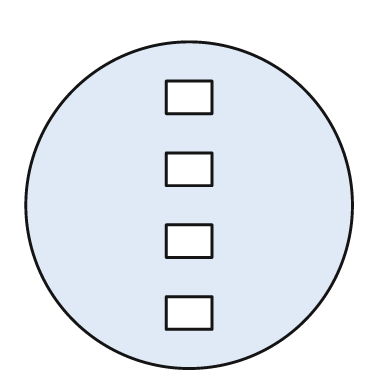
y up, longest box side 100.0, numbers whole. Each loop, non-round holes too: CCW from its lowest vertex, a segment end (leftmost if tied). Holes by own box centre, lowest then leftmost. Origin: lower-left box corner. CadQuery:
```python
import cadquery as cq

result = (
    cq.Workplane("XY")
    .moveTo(50.0, 50.0)
    .circle(50.0)
    .moveTo(43.0, 12.0)
    .lineTo(57.0, 12.0)
    .lineTo(57.0, 22.0)
    .lineTo(43.0, 22.0)
    .close()
    .moveTo(43.0, 34.0)
    .lineTo(57.0, 34.0)
    .lineTo(57.0, 44.0)
    .lineTo(43.0, 44.0)
    .close()
    .moveTo(43.0, 56.0)
    .lineTo(57.0, 56.0)
    .lineTo(57.0, 66.0)
    .lineTo(43.0, 66.0)
    .close()
    .moveTo(43.0, 78.0)
    .lineTo(57.0, 78.0)
    .lineTo(57.0, 88.0)
    .lineTo(43.0, 88.0)
    .close()
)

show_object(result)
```